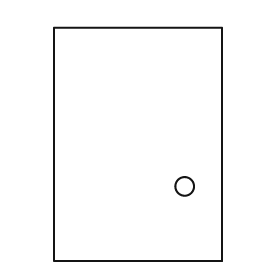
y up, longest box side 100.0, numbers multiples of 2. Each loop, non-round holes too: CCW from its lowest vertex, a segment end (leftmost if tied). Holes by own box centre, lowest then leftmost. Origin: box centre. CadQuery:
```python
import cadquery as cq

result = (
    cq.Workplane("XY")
    .moveTo(-36.0, -50.0)
    .lineTo(36.0, -50.0)
    .lineTo(36.0, 50.0)
    .lineTo(-36.0, 50.0)
    .close()
    .moveTo(20.0, -18.0)
    .circle(4.0)
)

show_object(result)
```